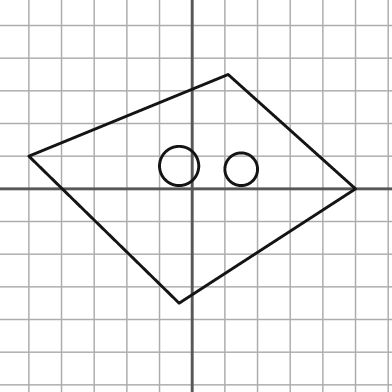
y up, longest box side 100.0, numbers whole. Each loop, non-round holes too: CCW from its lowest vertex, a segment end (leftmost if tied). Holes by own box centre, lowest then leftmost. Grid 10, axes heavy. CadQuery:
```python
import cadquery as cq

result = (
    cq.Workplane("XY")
    .moveTo(-4.0, -35.0)
    .lineTo(50.0, 0.0)
    .lineTo(11.0, 35.0)
    .lineTo(-50.0, 10.0)
    .close()
    .moveTo(15.0, 6.0)
    .circle(5.0)
    .moveTo(-4.0, 7.0)
    .circle(6.0)
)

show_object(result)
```